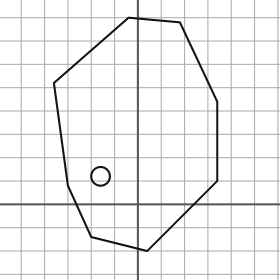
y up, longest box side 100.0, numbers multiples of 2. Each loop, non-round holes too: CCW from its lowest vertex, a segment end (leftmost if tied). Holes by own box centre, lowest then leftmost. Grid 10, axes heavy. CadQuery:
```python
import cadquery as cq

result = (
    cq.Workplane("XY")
    .moveTo(4.0, -20.0)
    .lineTo(34.0, 10.0)
    .lineTo(34.0, 44.0)
    .lineTo(18.0, 78.0)
    .lineTo(-4.0, 80.0)
    .lineTo(-36.0, 52.0)
    .lineTo(-30.0, 8.0)
    .lineTo(-20.0, -14.0)
    .close()
    .moveTo(-16.0, 12.0)
    .circle(4.0)
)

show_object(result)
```